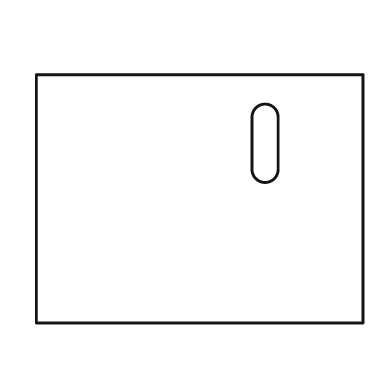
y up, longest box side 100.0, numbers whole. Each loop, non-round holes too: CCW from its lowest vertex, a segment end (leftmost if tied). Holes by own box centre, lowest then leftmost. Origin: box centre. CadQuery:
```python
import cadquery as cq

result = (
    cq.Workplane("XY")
    .moveTo(-50.0, -38.0)
    .lineTo(50.0, -38.0)
    .lineTo(50.0, 38.0)
    .lineTo(-50.0, 38.0)
    .close()
    .moveTo(16.0, 9.0)
    .threePointArc((20.0, 5.0), (24.0, 9.0))
    .lineTo(24.0, 25.0)
    .threePointArc((20.0, 29.0), (16.0, 25.0))
    .close()
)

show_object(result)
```